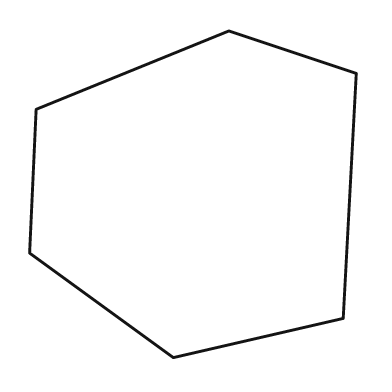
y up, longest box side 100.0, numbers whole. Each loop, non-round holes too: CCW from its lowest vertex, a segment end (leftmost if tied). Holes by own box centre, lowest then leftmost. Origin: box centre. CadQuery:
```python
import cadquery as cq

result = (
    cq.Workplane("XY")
    .moveTo(-6.0, -50.0)
    .lineTo(46.0, -38.0)
    .lineTo(50.0, 37.0)
    .lineTo(11.0, 50.0)
    .lineTo(-48.0, 26.0)
    .lineTo(-50.0, -18.0)
    .close()
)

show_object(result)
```